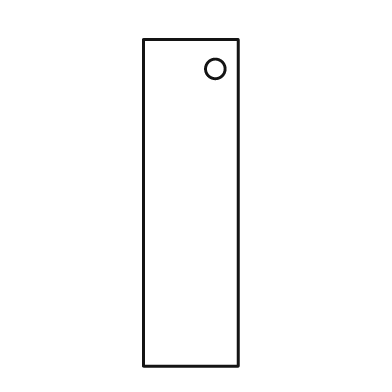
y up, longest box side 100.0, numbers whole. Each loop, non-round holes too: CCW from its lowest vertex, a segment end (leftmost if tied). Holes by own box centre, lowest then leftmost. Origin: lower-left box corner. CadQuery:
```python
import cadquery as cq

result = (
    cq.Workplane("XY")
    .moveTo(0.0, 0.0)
    .lineTo(29.0, 0.0)
    .lineTo(29.0, 100.0)
    .lineTo(0.0, 100.0)
    .close()
    .moveTo(22.0, 91.0)
    .circle(3.0)
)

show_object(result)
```